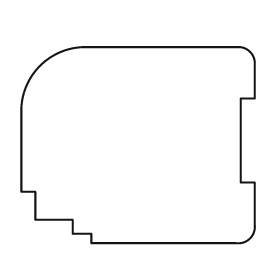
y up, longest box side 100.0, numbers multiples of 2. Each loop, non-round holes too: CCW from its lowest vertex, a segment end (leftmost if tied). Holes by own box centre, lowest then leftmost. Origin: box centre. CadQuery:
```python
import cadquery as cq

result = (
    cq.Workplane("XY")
    .moveTo(-20.0, -42.0)
    .lineTo(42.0, -42.0)
    .threePointArc((48.0, -40.0), (50.0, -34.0))
    .lineTo(50.0, -16.0)
    .lineTo(44.0, -16.0)
    .lineTo(44.0, 20.0)
    .lineTo(50.0, 20.0)
    .lineTo(50.0, 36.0)
    .threePointArc((48.0, 40.0), (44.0, 42.0))
    .lineTo(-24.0, 42.0)
    .threePointArc((-42.0, 34.0), (-50.0, 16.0))
    .lineTo(-50.0, -20.0)
    .lineTo(-44.0, -20.0)
    .lineTo(-44.0, -32.0)
    .lineTo(-28.0, -32.0)
    .lineTo(-28.0, -38.0)
    .lineTo(-20.0, -38.0)
    .close()
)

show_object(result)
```